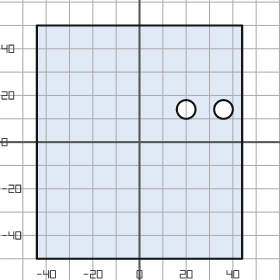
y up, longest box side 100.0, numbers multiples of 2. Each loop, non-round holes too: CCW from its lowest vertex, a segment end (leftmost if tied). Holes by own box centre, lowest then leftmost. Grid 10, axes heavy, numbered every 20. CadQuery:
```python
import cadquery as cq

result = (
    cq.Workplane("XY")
    .moveTo(-44.0, -50.0)
    .lineTo(44.0, -50.0)
    .lineTo(44.0, 50.0)
    .lineTo(-44.0, 50.0)
    .close()
    .moveTo(20.0, 14.0)
    .circle(4.0)
    .moveTo(36.0, 14.0)
    .circle(4.0)
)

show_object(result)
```